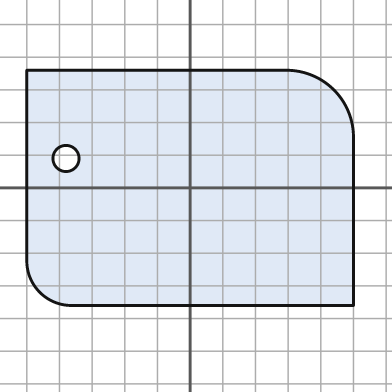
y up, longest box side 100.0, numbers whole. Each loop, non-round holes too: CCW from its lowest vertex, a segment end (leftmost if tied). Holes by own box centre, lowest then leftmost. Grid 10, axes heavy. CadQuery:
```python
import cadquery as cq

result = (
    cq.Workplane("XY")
    .moveTo(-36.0, -36.0)
    .lineTo(50.0, -36.0)
    .lineTo(50.0, 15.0)
    .threePointArc((44.0, 30.0), (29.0, 36.0))
    .lineTo(-50.0, 36.0)
    .lineTo(-50.0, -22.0)
    .threePointArc((-46.0, -32.0), (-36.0, -36.0))
    .close()
    .moveTo(-38.0, 9.0)
    .circle(4.0)
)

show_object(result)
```